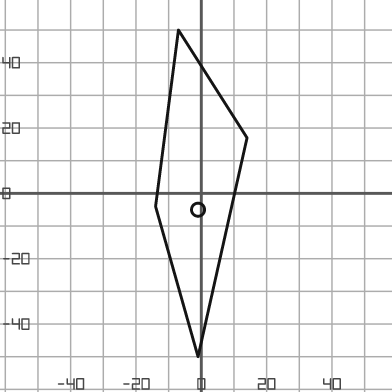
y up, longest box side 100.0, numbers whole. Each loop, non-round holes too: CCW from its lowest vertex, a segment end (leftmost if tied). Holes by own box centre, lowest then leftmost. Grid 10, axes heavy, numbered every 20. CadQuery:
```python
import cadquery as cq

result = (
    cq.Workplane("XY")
    .moveTo(-1.0, -50.0)
    .lineTo(14.0, 17.0)
    .lineTo(-7.0, 50.0)
    .lineTo(-14.0, -4.0)
    .close()
    .moveTo(-1.0, -5.0)
    .circle(2.0)
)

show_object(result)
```